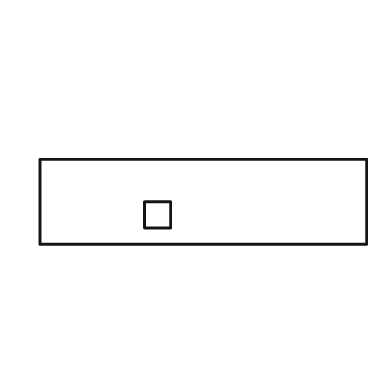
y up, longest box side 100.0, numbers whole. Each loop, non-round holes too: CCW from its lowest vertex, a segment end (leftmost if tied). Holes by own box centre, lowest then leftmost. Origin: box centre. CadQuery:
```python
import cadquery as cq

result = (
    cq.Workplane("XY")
    .moveTo(-50.0, -13.0)
    .lineTo(50.0, -13.0)
    .lineTo(50.0, 13.0)
    .lineTo(-50.0, 13.0)
    .close()
    .moveTo(-18.0, -8.0)
    .lineTo(-10.0, -8.0)
    .lineTo(-10.0, 0.0)
    .lineTo(-18.0, 0.0)
    .close()
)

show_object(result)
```